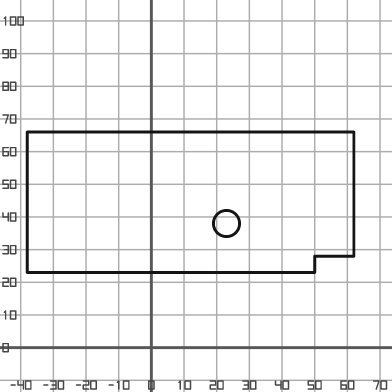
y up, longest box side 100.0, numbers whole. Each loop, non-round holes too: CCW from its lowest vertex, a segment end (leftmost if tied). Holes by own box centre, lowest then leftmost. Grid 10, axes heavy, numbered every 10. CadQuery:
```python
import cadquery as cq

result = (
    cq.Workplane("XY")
    .moveTo(-38.0, 23.0)
    .lineTo(50.0, 23.0)
    .lineTo(50.0, 28.0)
    .lineTo(62.0, 28.0)
    .lineTo(62.0, 66.0)
    .lineTo(-38.0, 66.0)
    .close()
    .moveTo(23.0, 38.0)
    .circle(4.0)
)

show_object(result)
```